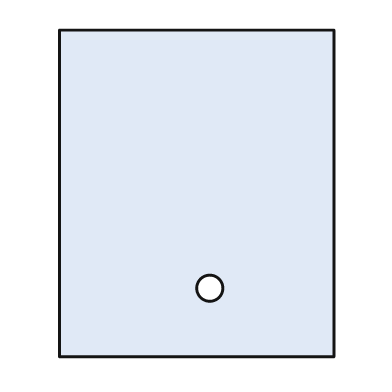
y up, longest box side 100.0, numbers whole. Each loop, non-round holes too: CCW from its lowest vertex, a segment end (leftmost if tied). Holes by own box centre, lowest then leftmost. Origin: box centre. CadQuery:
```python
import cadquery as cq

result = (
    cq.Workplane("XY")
    .moveTo(-42.0, -50.0)
    .lineTo(42.0, -50.0)
    .lineTo(42.0, 50.0)
    .lineTo(-42.0, 50.0)
    .close()
    .moveTo(4.0, -29.0)
    .circle(4.0)
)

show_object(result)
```